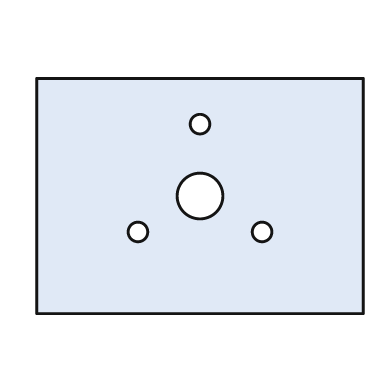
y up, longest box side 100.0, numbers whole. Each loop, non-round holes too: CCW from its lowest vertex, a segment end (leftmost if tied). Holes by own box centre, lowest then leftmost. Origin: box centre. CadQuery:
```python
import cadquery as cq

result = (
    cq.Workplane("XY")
    .moveTo(-50.0, -36.0)
    .lineTo(50.0, -36.0)
    .lineTo(50.0, 36.0)
    .lineTo(-50.0, 36.0)
    .close()
    .moveTo(-19.0, -11.0)
    .circle(3.0)
    .moveTo(19.0, -11.0)
    .circle(3.0)
    .moveTo(0.0, 0.0)
    .circle(7.0)
    .moveTo(0.0, 22.0)
    .circle(3.0)
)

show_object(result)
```